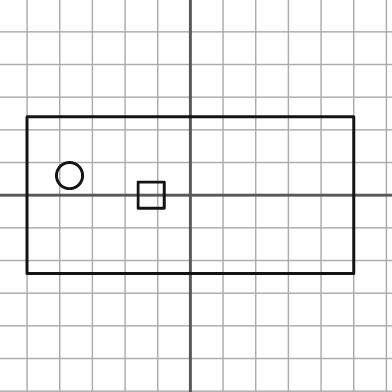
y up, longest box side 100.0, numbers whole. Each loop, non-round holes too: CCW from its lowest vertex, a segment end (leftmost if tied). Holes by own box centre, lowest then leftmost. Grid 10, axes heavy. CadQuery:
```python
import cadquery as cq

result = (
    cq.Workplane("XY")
    .moveTo(-50.0, -24.0)
    .lineTo(50.0, -24.0)
    .lineTo(50.0, 24.0)
    .lineTo(-50.0, 24.0)
    .close()
    .moveTo(-16.0, -4.0)
    .lineTo(-8.0, -4.0)
    .lineTo(-8.0, 4.0)
    .lineTo(-16.0, 4.0)
    .close()
    .moveTo(-37.0, 6.0)
    .circle(4.0)
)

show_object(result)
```